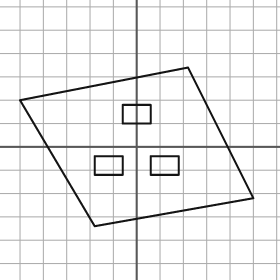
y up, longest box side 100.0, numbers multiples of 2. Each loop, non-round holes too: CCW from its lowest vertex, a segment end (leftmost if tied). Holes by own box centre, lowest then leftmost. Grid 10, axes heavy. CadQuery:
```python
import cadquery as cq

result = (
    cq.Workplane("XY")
    .moveTo(-18.0, -34.0)
    .lineTo(50.0, -22.0)
    .lineTo(22.0, 34.0)
    .lineTo(-50.0, 20.0)
    .close()
    .moveTo(-18.0, -12.0)
    .lineTo(-6.0, -12.0)
    .lineTo(-6.0, -4.0)
    .lineTo(-18.0, -4.0)
    .close()
    .moveTo(6.0, -12.0)
    .lineTo(18.0, -12.0)
    .lineTo(18.0, -4.0)
    .lineTo(6.0, -4.0)
    .close()
    .moveTo(-6.0, 10.0)
    .lineTo(6.0, 10.0)
    .lineTo(6.0, 18.0)
    .lineTo(-6.0, 18.0)
    .close()
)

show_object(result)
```